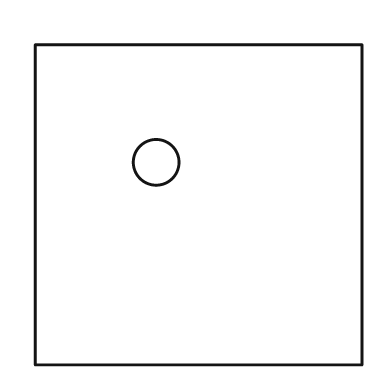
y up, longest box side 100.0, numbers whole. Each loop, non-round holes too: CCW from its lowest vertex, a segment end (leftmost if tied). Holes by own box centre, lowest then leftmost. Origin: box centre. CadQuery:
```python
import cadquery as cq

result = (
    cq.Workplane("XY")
    .moveTo(-50.0, -49.0)
    .lineTo(50.0, -49.0)
    .lineTo(50.0, 49.0)
    .lineTo(-50.0, 49.0)
    .close()
    .moveTo(-13.0, 13.0)
    .circle(7.0)
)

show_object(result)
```